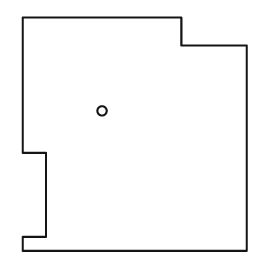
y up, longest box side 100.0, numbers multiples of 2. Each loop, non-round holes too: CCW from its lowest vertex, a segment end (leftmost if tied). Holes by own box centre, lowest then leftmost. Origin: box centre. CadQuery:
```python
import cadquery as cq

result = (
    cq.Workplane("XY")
    .moveTo(-48.0, -50.0)
    .lineTo(48.0, -50.0)
    .lineTo(48.0, 38.0)
    .lineTo(20.0, 38.0)
    .lineTo(20.0, 50.0)
    .lineTo(-48.0, 50.0)
    .lineTo(-48.0, -8.0)
    .lineTo(-38.0, -8.0)
    .lineTo(-38.0, -44.0)
    .lineTo(-48.0, -44.0)
    .close()
    .moveTo(-14.0, 10.0)
    .circle(2.0)
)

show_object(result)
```